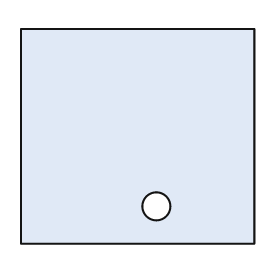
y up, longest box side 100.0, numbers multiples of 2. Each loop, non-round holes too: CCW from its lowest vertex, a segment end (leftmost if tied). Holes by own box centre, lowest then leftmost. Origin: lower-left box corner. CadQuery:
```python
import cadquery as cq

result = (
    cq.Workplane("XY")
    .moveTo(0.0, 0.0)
    .lineTo(100.0, 0.0)
    .lineTo(100.0, 92.0)
    .lineTo(0.0, 92.0)
    .close()
    .moveTo(58.0, 16.0)
    .circle(6.0)
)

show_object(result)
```